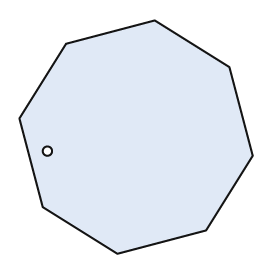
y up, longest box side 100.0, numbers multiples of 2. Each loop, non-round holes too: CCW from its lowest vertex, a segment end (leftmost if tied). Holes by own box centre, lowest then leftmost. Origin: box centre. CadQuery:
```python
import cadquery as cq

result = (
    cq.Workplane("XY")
    .moveTo(-8.0, -50.0)
    .lineTo(30.0, -40.0)
    .lineTo(50.0, -8.0)
    .lineTo(40.0, 30.0)
    .lineTo(8.0, 50.0)
    .lineTo(-30.0, 40.0)
    .lineTo(-50.0, 8.0)
    .lineTo(-40.0, -30.0)
    .close()
    .moveTo(-38.0, -6.0)
    .circle(2.0)
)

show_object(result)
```